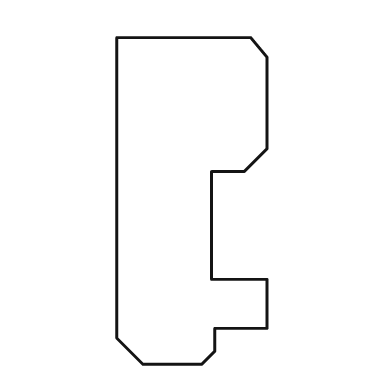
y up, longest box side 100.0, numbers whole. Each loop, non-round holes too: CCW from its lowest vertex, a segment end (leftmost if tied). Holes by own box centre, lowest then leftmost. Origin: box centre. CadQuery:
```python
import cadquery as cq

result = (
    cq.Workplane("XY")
    .moveTo(-15.0, -50.0)
    .lineTo(3.0, -50.0)
    .lineTo(7.0, -46.0)
    .lineTo(7.0, -39.0)
    .lineTo(23.0, -39.0)
    .lineTo(23.0, -24.0)
    .lineTo(6.0, -24.0)
    .lineTo(6.0, 9.0)
    .lineTo(16.0, 9.0)
    .lineTo(23.0, 16.0)
    .lineTo(23.0, 44.0)
    .lineTo(18.0, 50.0)
    .lineTo(-23.0, 50.0)
    .lineTo(-23.0, -42.0)
    .close()
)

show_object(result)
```